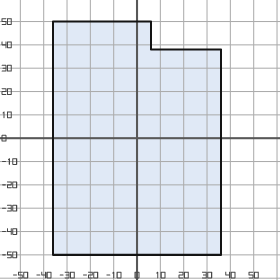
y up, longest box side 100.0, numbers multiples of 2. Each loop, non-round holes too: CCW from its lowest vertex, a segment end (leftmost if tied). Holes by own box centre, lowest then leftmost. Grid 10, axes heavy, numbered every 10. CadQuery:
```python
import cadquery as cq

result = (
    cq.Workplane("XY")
    .moveTo(-36.0, -50.0)
    .lineTo(36.0, -50.0)
    .lineTo(36.0, 38.0)
    .lineTo(6.0, 38.0)
    .lineTo(6.0, 50.0)
    .lineTo(-36.0, 50.0)
    .close()
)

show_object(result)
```